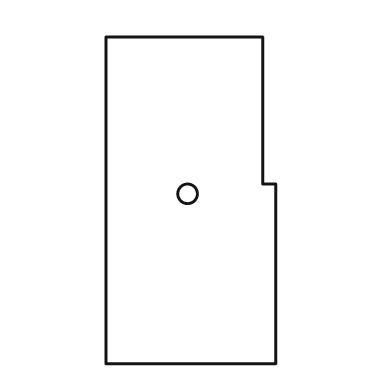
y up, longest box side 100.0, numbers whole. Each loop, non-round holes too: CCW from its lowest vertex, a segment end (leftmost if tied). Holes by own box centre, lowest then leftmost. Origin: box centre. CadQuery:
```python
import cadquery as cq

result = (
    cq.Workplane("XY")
    .moveTo(-26.0, -50.0)
    .lineTo(26.0, -50.0)
    .lineTo(26.0, 5.0)
    .lineTo(22.0, 5.0)
    .lineTo(22.0, 50.0)
    .lineTo(-26.0, 50.0)
    .close()
    .moveTo(-1.0, 2.0)
    .circle(3.0)
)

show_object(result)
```